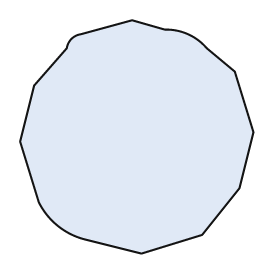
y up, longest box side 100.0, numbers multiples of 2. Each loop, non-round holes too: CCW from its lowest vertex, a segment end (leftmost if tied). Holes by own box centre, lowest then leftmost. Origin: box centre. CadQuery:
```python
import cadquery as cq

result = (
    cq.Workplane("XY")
    .moveTo(2.0, -50.0)
    .lineTo(28.0, -42.0)
    .lineTo(44.0, -22.0)
    .lineTo(50.0, 2.0)
    .lineTo(42.0, 28.0)
    .lineTo(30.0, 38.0)
    .threePointArc((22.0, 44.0), (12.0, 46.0))
    .lineTo(-2.0, 50.0)
    .lineTo(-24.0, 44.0)
    .threePointArc((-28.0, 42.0), (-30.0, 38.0))
    .lineTo(-44.0, 22.0)
    .lineTo(-50.0, -2.0)
    .lineTo(-42.0, -28.0)
    .threePointArc((-34.0, -38.0), (-22.0, -44.0))
    .close()
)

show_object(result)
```